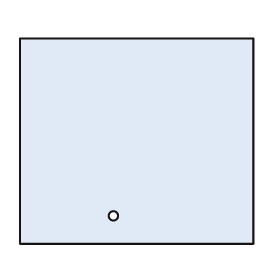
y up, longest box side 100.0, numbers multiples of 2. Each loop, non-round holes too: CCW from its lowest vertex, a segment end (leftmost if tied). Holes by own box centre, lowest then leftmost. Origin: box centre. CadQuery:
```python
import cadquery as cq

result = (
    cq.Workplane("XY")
    .moveTo(-50.0, -44.0)
    .lineTo(50.0, -44.0)
    .lineTo(50.0, 44.0)
    .lineTo(-50.0, 44.0)
    .close()
    .moveTo(-10.0, -32.0)
    .circle(2.0)
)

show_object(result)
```